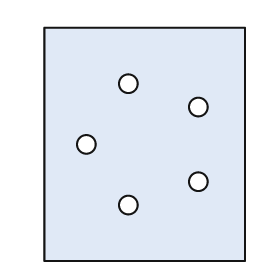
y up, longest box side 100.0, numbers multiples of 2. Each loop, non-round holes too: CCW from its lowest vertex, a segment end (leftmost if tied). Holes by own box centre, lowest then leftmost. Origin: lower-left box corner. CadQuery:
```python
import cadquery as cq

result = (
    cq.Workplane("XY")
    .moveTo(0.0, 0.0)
    .lineTo(86.0, 0.0)
    .lineTo(86.0, 100.0)
    .lineTo(0.0, 100.0)
    .close()
    .moveTo(36.0, 24.0)
    .circle(4.0)
    .moveTo(66.0, 34.0)
    .circle(4.0)
    .moveTo(18.0, 50.0)
    .circle(4.0)
    .moveTo(66.0, 66.0)
    .circle(4.0)
    .moveTo(36.0, 76.0)
    .circle(4.0)
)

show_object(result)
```